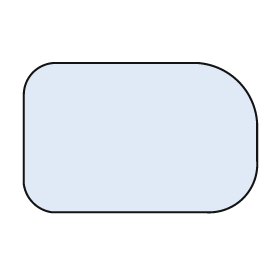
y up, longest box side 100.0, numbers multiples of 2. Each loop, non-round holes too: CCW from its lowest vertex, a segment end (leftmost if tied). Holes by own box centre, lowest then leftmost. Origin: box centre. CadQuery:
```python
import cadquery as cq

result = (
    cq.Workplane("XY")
    .moveTo(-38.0, -32.0)
    .lineTo(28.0, -32.0)
    .threePointArc((44.0, -26.0), (50.0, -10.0))
    .lineTo(50.0, 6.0)
    .threePointArc((42.0, 24.0), (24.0, 32.0))
    .lineTo(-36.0, 32.0)
    .threePointArc((-46.0, 28.0), (-50.0, 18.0))
    .lineTo(-50.0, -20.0)
    .threePointArc((-46.0, -28.0), (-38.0, -32.0))
    .close()
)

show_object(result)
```